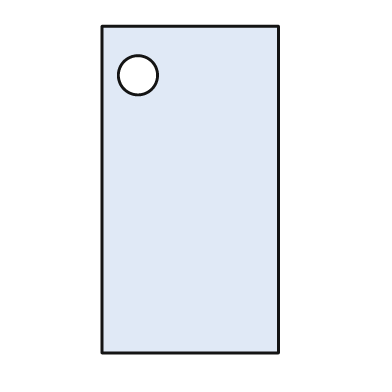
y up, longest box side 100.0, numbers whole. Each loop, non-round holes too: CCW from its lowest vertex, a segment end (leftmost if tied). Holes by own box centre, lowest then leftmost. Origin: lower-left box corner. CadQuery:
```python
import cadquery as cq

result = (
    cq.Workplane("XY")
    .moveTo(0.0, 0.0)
    .lineTo(54.0, 0.0)
    .lineTo(54.0, 100.0)
    .lineTo(0.0, 100.0)
    .close()
    .moveTo(11.0, 85.0)
    .circle(6.0)
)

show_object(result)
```